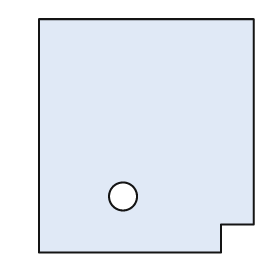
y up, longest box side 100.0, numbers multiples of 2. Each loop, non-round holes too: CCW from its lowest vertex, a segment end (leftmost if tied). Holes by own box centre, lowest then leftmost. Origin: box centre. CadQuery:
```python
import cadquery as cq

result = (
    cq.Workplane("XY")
    .moveTo(-46.0, -50.0)
    .lineTo(32.0, -50.0)
    .lineTo(32.0, -38.0)
    .lineTo(46.0, -38.0)
    .lineTo(46.0, 50.0)
    .lineTo(-46.0, 50.0)
    .close()
    .moveTo(-10.0, -26.0)
    .circle(6.0)
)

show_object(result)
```